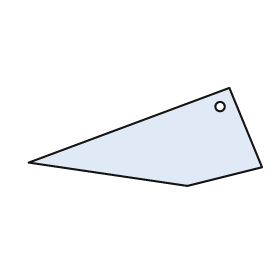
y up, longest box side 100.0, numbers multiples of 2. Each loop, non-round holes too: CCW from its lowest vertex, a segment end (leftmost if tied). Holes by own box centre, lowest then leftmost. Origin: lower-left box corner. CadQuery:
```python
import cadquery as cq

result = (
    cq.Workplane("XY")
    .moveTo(68.0, 0.0)
    .lineTo(100.0, 8.0)
    .lineTo(86.0, 42.0)
    .lineTo(0.0, 10.0)
    .close()
    .moveTo(82.0, 34.0)
    .circle(2.0)
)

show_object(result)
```